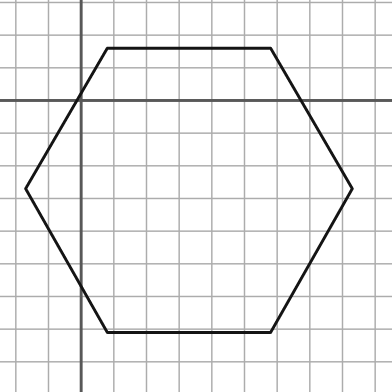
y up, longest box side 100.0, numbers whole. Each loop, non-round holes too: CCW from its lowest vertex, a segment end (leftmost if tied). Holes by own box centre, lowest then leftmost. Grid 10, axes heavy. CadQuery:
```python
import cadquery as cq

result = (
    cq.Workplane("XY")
    .moveTo(8.0, -71.0)
    .lineTo(58.0, -71.0)
    .lineTo(83.0, -27.0)
    .lineTo(58.0, 16.0)
    .lineTo(8.0, 16.0)
    .lineTo(-17.0, -27.0)
    .close()
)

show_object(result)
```